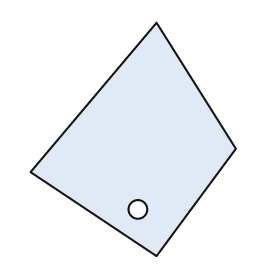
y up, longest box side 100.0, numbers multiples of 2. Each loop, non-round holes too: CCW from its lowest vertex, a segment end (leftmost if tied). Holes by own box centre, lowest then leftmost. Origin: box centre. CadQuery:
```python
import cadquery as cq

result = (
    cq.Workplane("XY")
    .moveTo(10.0, -50.0)
    .lineTo(44.0, -4.0)
    .lineTo(10.0, 50.0)
    .lineTo(-44.0, -14.0)
    .close()
    .moveTo(2.0, -30.0)
    .circle(4.0)
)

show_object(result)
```